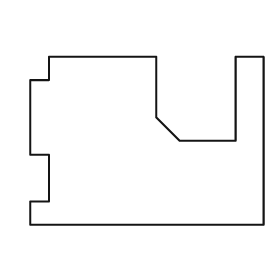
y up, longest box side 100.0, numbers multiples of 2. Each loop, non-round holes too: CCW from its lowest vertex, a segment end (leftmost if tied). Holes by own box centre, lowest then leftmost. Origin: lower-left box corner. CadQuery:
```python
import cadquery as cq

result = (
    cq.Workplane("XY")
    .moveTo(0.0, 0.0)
    .lineTo(100.0, 0.0)
    .lineTo(100.0, 72.0)
    .lineTo(88.0, 72.0)
    .lineTo(88.0, 36.0)
    .lineTo(64.0, 36.0)
    .lineTo(54.0, 46.0)
    .lineTo(54.0, 72.0)
    .lineTo(8.0, 72.0)
    .lineTo(8.0, 62.0)
    .lineTo(0.0, 62.0)
    .lineTo(0.0, 30.0)
    .lineTo(8.0, 30.0)
    .lineTo(8.0, 10.0)
    .lineTo(0.0, 10.0)
    .close()
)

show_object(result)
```